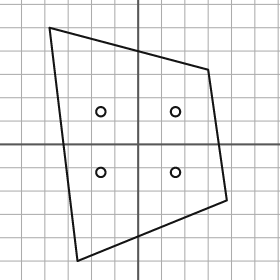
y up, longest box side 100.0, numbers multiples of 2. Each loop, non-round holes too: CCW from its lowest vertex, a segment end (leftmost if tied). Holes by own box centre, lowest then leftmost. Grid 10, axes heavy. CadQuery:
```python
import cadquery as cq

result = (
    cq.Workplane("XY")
    .moveTo(-26.0, -50.0)
    .lineTo(38.0, -24.0)
    .lineTo(30.0, 32.0)
    .lineTo(-38.0, 50.0)
    .close()
    .moveTo(-16.0, -12.0)
    .circle(2.0)
    .moveTo(16.0, -12.0)
    .circle(2.0)
    .moveTo(-16.0, 14.0)
    .circle(2.0)
    .moveTo(16.0, 14.0)
    .circle(2.0)
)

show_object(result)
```